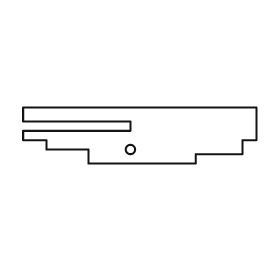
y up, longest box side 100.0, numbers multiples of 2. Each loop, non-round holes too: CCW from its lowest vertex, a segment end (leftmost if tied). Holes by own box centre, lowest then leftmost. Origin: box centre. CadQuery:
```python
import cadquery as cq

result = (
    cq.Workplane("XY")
    .moveTo(-22.0, -12.0)
    .lineTo(24.0, -12.0)
    .lineTo(24.0, -8.0)
    .lineTo(44.0, -8.0)
    .lineTo(44.0, -2.0)
    .lineTo(50.0, -2.0)
    .lineTo(50.0, 12.0)
    .lineTo(-50.0, 12.0)
    .lineTo(-50.0, 6.0)
    .lineTo(-4.0, 6.0)
    .lineTo(-4.0, 2.0)
    .lineTo(-50.0, 2.0)
    .lineTo(-50.0, -2.0)
    .lineTo(-40.0, -2.0)
    .lineTo(-40.0, -6.0)
    .lineTo(-22.0, -6.0)
    .close()
    .moveTo(-4.0, -6.0)
    .circle(2.0)
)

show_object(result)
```